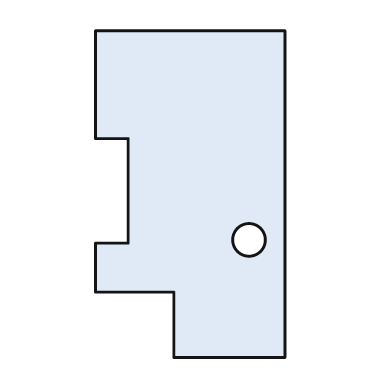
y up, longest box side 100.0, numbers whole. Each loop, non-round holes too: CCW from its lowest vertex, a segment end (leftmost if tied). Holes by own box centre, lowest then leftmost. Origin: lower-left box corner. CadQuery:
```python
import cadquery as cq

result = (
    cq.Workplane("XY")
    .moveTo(24.0, 0.0)
    .lineTo(58.0, 0.0)
    .lineTo(58.0, 100.0)
    .lineTo(0.0, 100.0)
    .lineTo(0.0, 67.0)
    .lineTo(10.0, 67.0)
    .lineTo(10.0, 35.0)
    .lineTo(0.0, 35.0)
    .lineTo(0.0, 20.0)
    .lineTo(24.0, 20.0)
    .close()
    .moveTo(47.0, 36.0)
    .circle(5.0)
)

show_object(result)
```